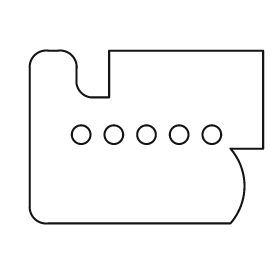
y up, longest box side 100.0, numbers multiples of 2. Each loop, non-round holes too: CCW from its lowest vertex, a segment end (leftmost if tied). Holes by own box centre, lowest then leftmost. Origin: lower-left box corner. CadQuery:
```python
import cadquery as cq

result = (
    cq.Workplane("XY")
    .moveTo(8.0, 0.0)
    .lineTo(86.0, 0.0)
    .threePointArc((92.0, 16.0), (86.0, 32.0))
    .lineTo(100.0, 32.0)
    .lineTo(100.0, 74.0)
    .lineTo(34.0, 74.0)
    .lineTo(34.0, 54.0)
    .lineTo(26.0, 54.0)
    .threePointArc((22.0, 56.0), (20.0, 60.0))
    .lineTo(20.0, 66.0)
    .threePointArc((18.0, 72.0), (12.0, 74.0))
    .lineTo(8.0, 74.0)
    .threePointArc((2.0, 72.0), (0.0, 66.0))
    .lineTo(0.0, 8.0)
    .threePointArc((2.0, 2.0), (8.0, 0.0))
    .close()
    .moveTo(22.0, 38.0)
    .circle(4.0)
    .moveTo(36.0, 38.0)
    .circle(4.0)
    .moveTo(50.0, 38.0)
    .circle(4.0)
    .moveTo(64.0, 38.0)
    .circle(4.0)
    .moveTo(78.0, 38.0)
    .circle(4.0)
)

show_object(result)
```